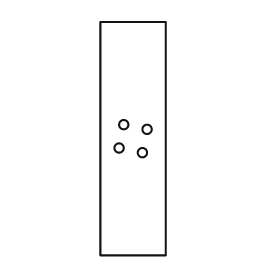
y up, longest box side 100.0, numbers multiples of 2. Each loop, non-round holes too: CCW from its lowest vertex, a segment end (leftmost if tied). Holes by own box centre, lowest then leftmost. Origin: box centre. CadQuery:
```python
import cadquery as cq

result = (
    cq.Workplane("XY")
    .moveTo(-14.0, -50.0)
    .lineTo(14.0, -50.0)
    .lineTo(14.0, 50.0)
    .lineTo(-14.0, 50.0)
    .close()
    .moveTo(4.0, -6.0)
    .circle(2.0)
    .moveTo(-6.0, -4.0)
    .circle(2.0)
    .moveTo(6.0, 4.0)
    .circle(2.0)
    .moveTo(-4.0, 6.0)
    .circle(2.0)
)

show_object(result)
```